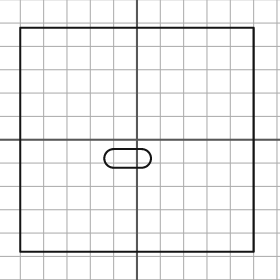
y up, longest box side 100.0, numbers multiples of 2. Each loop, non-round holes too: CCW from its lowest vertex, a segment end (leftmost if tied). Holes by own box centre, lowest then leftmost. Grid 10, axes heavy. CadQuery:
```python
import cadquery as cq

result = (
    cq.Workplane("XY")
    .moveTo(-50.0, -48.0)
    .lineTo(50.0, -48.0)
    .lineTo(50.0, 48.0)
    .lineTo(-50.0, 48.0)
    .close()
    .moveTo(-10.0, -12.0)
    .lineTo(2.0, -12.0)
    .threePointArc((6.0, -8.0), (2.0, -4.0))
    .lineTo(-10.0, -4.0)
    .threePointArc((-14.0, -8.0), (-10.0, -12.0))
    .close()
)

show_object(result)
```